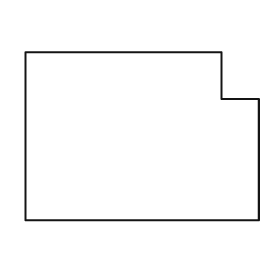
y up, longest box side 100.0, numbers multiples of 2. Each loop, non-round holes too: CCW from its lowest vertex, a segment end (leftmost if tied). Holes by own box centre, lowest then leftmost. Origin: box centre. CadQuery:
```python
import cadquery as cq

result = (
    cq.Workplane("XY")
    .moveTo(-50.0, -36.0)
    .lineTo(50.0, -36.0)
    .lineTo(50.0, 16.0)
    .lineTo(34.0, 16.0)
    .lineTo(34.0, 36.0)
    .lineTo(-50.0, 36.0)
    .close()
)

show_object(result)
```